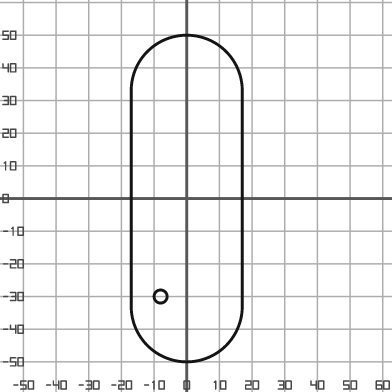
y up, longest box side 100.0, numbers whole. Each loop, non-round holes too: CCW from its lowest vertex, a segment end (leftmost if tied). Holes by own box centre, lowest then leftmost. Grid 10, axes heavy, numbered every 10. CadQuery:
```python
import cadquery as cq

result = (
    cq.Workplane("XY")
    .moveTo(-17.0, -33.0)
    .threePointArc((0.0, -50.0), (17.0, -33.0))
    .lineTo(17.0, 33.0)
    .threePointArc((0.0, 50.0), (-17.0, 33.0))
    .close()
    .moveTo(-8.0, -30.0)
    .circle(2.0)
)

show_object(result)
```